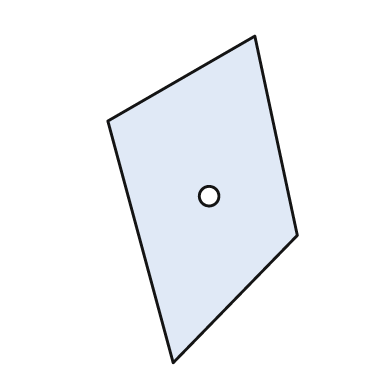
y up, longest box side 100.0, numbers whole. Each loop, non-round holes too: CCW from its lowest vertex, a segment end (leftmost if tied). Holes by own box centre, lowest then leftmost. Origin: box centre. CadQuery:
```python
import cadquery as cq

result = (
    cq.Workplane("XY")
    .moveTo(-9.0, -50.0)
    .lineTo(29.0, -11.0)
    .lineTo(16.0, 50.0)
    .lineTo(-29.0, 24.0)
    .close()
    .moveTo(2.0, 1.0)
    .circle(3.0)
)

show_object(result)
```